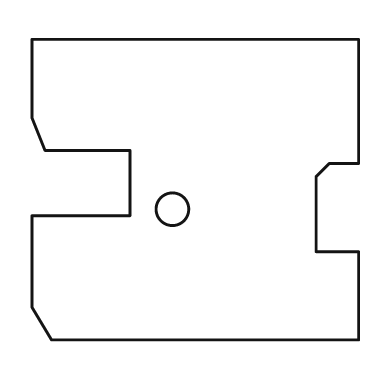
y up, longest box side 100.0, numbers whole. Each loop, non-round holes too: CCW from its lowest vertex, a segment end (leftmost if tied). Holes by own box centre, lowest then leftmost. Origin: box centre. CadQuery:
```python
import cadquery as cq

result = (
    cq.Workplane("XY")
    .moveTo(-44.0, -46.0)
    .lineTo(50.0, -46.0)
    .lineTo(50.0, -19.0)
    .lineTo(37.0, -19.0)
    .lineTo(37.0, 4.0)
    .lineTo(41.0, 8.0)
    .lineTo(50.0, 8.0)
    .lineTo(50.0, 46.0)
    .lineTo(-50.0, 46.0)
    .lineTo(-50.0, 22.0)
    .lineTo(-46.0, 12.0)
    .lineTo(-20.0, 12.0)
    .lineTo(-20.0, -8.0)
    .lineTo(-50.0, -8.0)
    .lineTo(-50.0, -36.0)
    .close()
    .moveTo(-7.0, -6.0)
    .circle(5.0)
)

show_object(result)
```